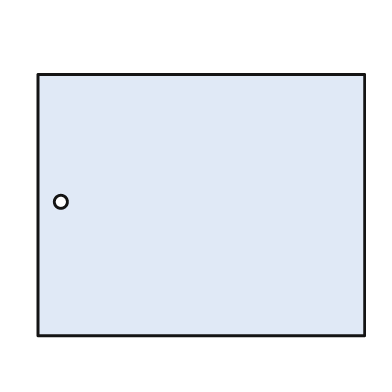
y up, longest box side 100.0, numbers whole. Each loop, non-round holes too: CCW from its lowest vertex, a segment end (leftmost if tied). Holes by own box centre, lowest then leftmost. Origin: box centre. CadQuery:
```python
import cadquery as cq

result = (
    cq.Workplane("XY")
    .moveTo(-50.0, -40.0)
    .lineTo(50.0, -40.0)
    .lineTo(50.0, 40.0)
    .lineTo(-50.0, 40.0)
    .close()
    .moveTo(-43.0, 1.0)
    .circle(2.0)
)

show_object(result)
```